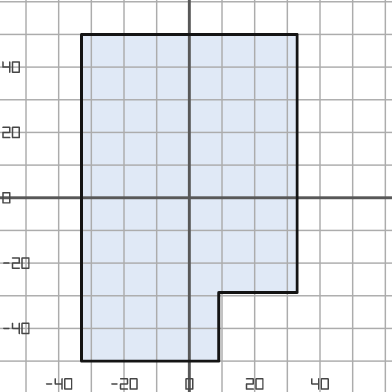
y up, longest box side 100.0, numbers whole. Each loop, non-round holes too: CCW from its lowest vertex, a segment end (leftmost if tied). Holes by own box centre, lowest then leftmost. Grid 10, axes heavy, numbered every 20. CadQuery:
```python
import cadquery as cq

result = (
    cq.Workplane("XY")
    .moveTo(-33.0, -50.0)
    .lineTo(9.0, -50.0)
    .lineTo(9.0, -29.0)
    .lineTo(33.0, -29.0)
    .lineTo(33.0, 50.0)
    .lineTo(-33.0, 50.0)
    .close()
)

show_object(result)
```